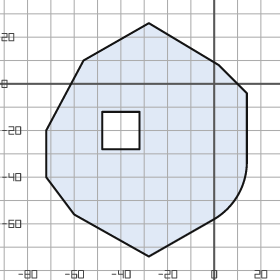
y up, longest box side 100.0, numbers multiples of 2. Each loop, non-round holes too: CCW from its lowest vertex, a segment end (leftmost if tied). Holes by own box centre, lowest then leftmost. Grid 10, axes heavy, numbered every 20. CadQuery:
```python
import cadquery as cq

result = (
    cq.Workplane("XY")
    .moveTo(-28.0, -74.0)
    .lineTo(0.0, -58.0)
    .threePointArc((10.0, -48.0), (14.0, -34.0))
    .lineTo(14.0, -4.0)
    .lineTo(2.0, 8.0)
    .lineTo(-28.0, 26.0)
    .lineTo(-56.0, 10.0)
    .lineTo(-72.0, -20.0)
    .lineTo(-72.0, -40.0)
    .lineTo(-60.0, -56.0)
    .close()
    .moveTo(-48.0, -28.0)
    .lineTo(-32.0, -28.0)
    .lineTo(-32.0, -12.0)
    .lineTo(-48.0, -12.0)
    .close()
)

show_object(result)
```